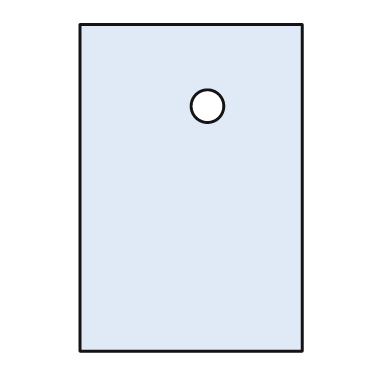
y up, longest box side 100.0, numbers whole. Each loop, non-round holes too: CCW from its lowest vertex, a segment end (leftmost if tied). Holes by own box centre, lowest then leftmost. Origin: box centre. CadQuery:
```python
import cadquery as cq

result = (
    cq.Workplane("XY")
    .moveTo(-34.0, -50.0)
    .lineTo(34.0, -50.0)
    .lineTo(34.0, 50.0)
    .lineTo(-34.0, 50.0)
    .close()
    .moveTo(5.0, 25.0)
    .circle(5.0)
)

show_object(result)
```